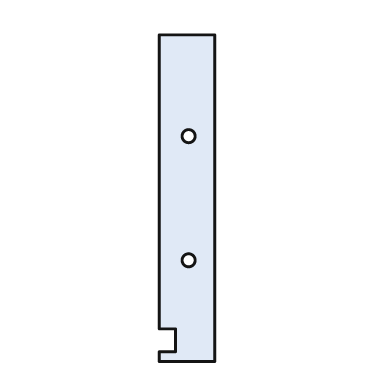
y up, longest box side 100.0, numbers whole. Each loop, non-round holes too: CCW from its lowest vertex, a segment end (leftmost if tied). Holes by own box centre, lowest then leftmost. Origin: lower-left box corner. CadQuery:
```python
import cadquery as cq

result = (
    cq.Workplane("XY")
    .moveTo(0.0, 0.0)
    .lineTo(17.0, 0.0)
    .lineTo(17.0, 100.0)
    .lineTo(0.0, 100.0)
    .lineTo(0.0, 10.0)
    .lineTo(5.0, 10.0)
    .lineTo(5.0, 3.0)
    .lineTo(0.0, 3.0)
    .close()
    .moveTo(9.0, 31.0)
    .circle(2.0)
    .moveTo(9.0, 69.0)
    .circle(2.0)
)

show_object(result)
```